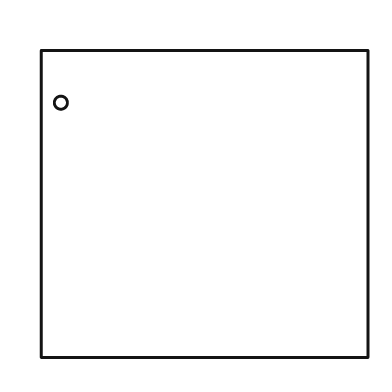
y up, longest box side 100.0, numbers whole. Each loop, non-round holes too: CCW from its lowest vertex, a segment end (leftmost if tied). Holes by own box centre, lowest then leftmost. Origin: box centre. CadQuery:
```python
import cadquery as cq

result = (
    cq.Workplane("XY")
    .moveTo(-50.0, -47.0)
    .lineTo(50.0, -47.0)
    .lineTo(50.0, 47.0)
    .lineTo(-50.0, 47.0)
    .close()
    .moveTo(-44.0, 31.0)
    .circle(2.0)
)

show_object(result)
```